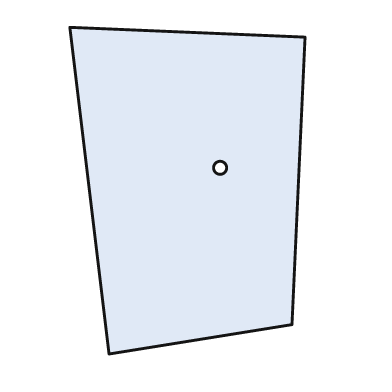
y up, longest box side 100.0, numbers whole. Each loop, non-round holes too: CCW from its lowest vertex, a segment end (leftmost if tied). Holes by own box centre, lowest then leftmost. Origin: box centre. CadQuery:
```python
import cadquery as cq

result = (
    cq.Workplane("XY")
    .moveTo(-24.0, -50.0)
    .lineTo(32.0, -41.0)
    .lineTo(36.0, 47.0)
    .lineTo(-36.0, 50.0)
    .close()
    .moveTo(10.0, 7.0)
    .circle(2.0)
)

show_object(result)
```